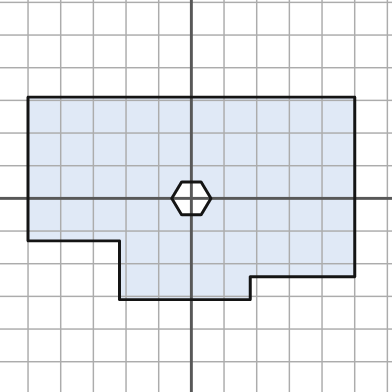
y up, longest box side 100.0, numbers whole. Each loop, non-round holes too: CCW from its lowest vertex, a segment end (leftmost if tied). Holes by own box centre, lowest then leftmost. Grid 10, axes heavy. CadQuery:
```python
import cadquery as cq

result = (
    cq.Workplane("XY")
    .moveTo(-22.0, -31.0)
    .lineTo(18.0, -31.0)
    .lineTo(18.0, -24.0)
    .lineTo(50.0, -24.0)
    .lineTo(50.0, 31.0)
    .lineTo(-50.0, 31.0)
    .lineTo(-50.0, -13.0)
    .lineTo(-22.0, -13.0)
    .close()
    .moveTo(-3.0, -5.0)
    .lineTo(3.0, -5.0)
    .lineTo(6.0, 0.0)
    .lineTo(3.0, 5.0)
    .lineTo(-3.0, 5.0)
    .lineTo(-6.0, 0.0)
    .close()
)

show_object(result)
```